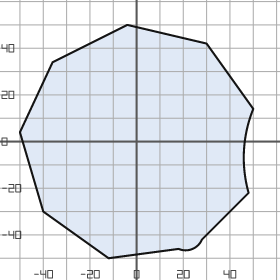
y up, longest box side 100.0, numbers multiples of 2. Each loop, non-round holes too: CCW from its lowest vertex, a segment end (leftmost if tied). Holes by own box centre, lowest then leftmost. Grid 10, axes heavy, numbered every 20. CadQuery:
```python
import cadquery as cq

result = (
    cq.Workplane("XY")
    .moveTo(-12.0, -50.0)
    .lineTo(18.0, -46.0)
    .threePointArc((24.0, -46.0), (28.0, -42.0))
    .lineTo(48.0, -22.0)
    .threePointArc((46.0, -4.0), (50.0, 14.0))
    .lineTo(30.0, 42.0)
    .lineTo(-4.0, 50.0)
    .lineTo(-36.0, 34.0)
    .lineTo(-50.0, 4.0)
    .lineTo(-40.0, -30.0)
    .close()
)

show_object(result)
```